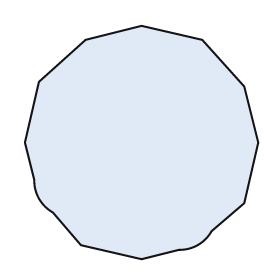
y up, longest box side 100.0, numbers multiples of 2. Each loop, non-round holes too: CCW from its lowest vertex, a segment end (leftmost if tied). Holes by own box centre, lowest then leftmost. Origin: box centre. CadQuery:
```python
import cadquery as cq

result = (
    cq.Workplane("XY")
    .moveTo(0.0, -50.0)
    .lineTo(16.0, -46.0)
    .threePointArc((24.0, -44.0), (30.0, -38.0))
    .lineTo(44.0, -26.0)
    .lineTo(50.0, 0.0)
    .lineTo(44.0, 24.0)
    .lineTo(26.0, 44.0)
    .lineTo(0.0, 50.0)
    .lineTo(-24.0, 44.0)
    .lineTo(-44.0, 26.0)
    .lineTo(-50.0, 0.0)
    .lineTo(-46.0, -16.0)
    .threePointArc((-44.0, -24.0), (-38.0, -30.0))
    .lineTo(-26.0, -44.0)
    .close()
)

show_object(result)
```